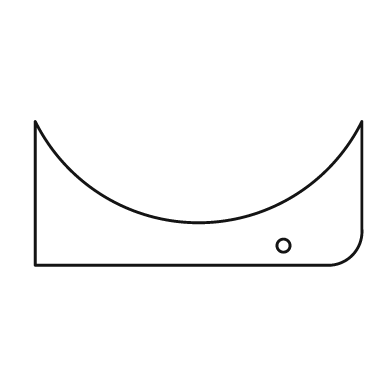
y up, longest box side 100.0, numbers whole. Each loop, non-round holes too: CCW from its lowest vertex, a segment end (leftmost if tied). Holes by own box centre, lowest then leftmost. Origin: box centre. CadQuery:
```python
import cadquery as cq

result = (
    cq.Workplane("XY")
    .moveTo(-50.0, -22.0)
    .lineTo(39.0, -22.0)
    .threePointArc((47.0, -19.0), (50.0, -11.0))
    .lineTo(50.0, 22.0)
    .threePointArc((0.0, -9.0), (-50.0, 22.0))
    .close()
    .moveTo(26.0, -16.0)
    .circle(2.0)
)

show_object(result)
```